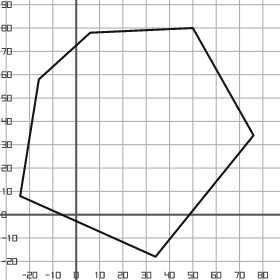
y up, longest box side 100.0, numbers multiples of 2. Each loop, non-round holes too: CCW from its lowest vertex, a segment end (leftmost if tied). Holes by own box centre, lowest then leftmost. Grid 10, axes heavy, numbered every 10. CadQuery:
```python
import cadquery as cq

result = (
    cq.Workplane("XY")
    .moveTo(34.0, -18.0)
    .lineTo(76.0, 34.0)
    .lineTo(50.0, 80.0)
    .lineTo(6.0, 78.0)
    .lineTo(-16.0, 58.0)
    .lineTo(-24.0, 8.0)
    .close()
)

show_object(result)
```